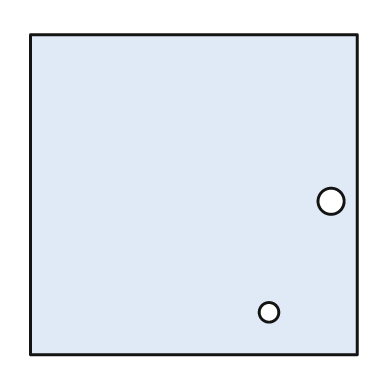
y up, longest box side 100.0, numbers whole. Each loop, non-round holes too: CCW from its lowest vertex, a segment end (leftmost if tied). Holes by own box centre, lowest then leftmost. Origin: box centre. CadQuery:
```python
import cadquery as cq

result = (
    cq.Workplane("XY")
    .moveTo(-50.0, -49.0)
    .lineTo(50.0, -49.0)
    .lineTo(50.0, 49.0)
    .lineTo(-50.0, 49.0)
    .close()
    .moveTo(23.0, -36.0)
    .circle(3.0)
    .moveTo(42.0, -2.0)
    .circle(4.0)
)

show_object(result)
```